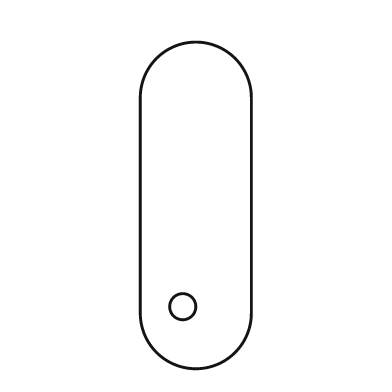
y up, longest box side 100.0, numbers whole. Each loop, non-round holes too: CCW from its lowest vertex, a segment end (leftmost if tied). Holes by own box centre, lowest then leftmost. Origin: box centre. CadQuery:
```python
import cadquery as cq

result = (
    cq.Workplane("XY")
    .moveTo(-17.0, -33.0)
    .threePointArc((0.0, -50.0), (17.0, -33.0))
    .lineTo(17.0, 33.0)
    .threePointArc((0.0, 50.0), (-17.0, 33.0))
    .close()
    .moveTo(-4.0, -31.0)
    .circle(4.0)
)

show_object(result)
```